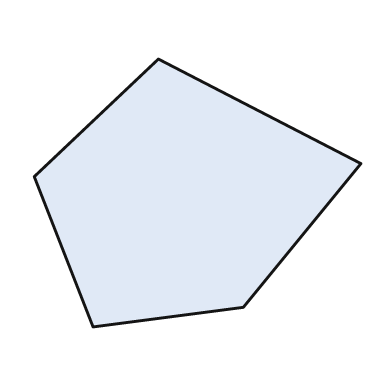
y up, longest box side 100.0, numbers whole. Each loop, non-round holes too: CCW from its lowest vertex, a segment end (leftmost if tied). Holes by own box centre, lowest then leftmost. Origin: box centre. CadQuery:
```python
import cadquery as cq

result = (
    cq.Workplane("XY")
    .moveTo(-32.0, -41.0)
    .lineTo(14.0, -35.0)
    .lineTo(50.0, 9.0)
    .lineTo(-12.0, 41.0)
    .lineTo(-50.0, 5.0)
    .close()
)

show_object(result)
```